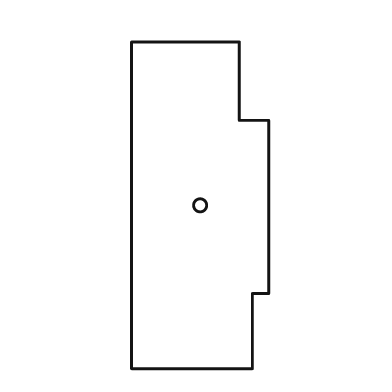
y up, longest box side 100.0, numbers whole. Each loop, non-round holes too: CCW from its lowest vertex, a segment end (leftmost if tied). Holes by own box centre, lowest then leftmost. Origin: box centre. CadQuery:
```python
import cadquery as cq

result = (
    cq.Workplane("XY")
    .moveTo(-21.0, -50.0)
    .lineTo(16.0, -50.0)
    .lineTo(16.0, -27.0)
    .lineTo(21.0, -27.0)
    .lineTo(21.0, 26.0)
    .lineTo(12.0, 26.0)
    .lineTo(12.0, 50.0)
    .lineTo(-21.0, 50.0)
    .close()
    .moveTo(0.0, 0.0)
    .circle(2.0)
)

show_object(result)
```